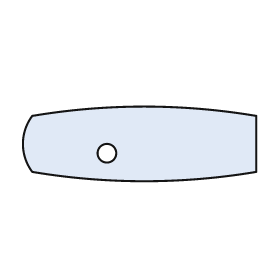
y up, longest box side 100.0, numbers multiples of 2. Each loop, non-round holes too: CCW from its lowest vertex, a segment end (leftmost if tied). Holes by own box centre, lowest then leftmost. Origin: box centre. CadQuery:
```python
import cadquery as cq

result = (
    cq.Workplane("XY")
    .moveTo(-46.0, -12.0)
    .threePointArc((2.0, -16.0), (50.0, -12.0))
    .lineTo(50.0, 12.0)
    .threePointArc((2.0, 16.0), (-46.0, 12.0))
    .threePointArc((-50.0, 0.0), (-46.0, -12.0))
    .close()
    .moveTo(-14.0, -4.0)
    .circle(4.0)
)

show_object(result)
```